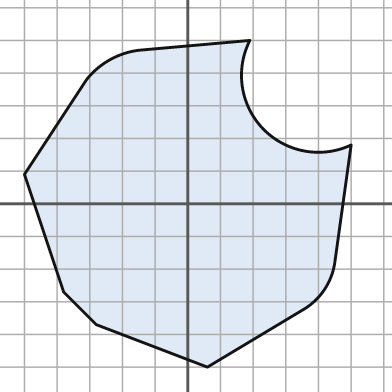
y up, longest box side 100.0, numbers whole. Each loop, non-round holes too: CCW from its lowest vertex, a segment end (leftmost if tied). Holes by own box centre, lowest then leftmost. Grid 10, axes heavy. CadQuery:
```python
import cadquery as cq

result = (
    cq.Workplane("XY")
    .moveTo(6.0, -50.0)
    .lineTo(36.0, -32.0)
    .threePointArc((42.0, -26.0), (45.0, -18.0))
    .lineTo(50.0, 18.0)
    .threePointArc((23.0, 23.0), (19.0, 50.0))
    .lineTo(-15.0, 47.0)
    .threePointArc((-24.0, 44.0), (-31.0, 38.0))
    .lineTo(-50.0, 9.0)
    .lineTo(-38.0, -27.0)
    .lineTo(-28.0, -37.0)
    .close()
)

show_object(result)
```